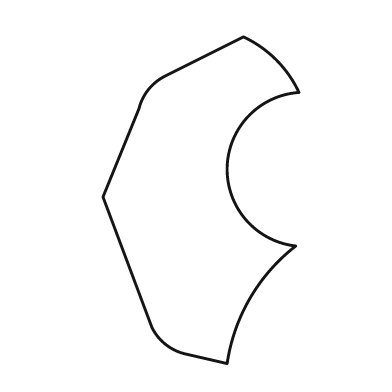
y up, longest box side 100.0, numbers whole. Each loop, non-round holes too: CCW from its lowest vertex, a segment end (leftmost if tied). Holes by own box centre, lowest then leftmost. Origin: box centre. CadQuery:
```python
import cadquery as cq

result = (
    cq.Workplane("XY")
    .moveTo(8.0, -50.0)
    .threePointArc((15.0, -30.0), (29.0, -14.0))
    .threePointArc((8.0, 10.0), (30.0, 33.0))
    .threePointArc((23.0, 43.0), (13.0, 50.0))
    .lineTo(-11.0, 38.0)
    .threePointArc((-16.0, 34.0), (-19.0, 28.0))
    .lineTo(-30.0, 1.0)
    .lineTo(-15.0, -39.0)
    .threePointArc((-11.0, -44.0), (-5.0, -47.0))
    .close()
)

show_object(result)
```